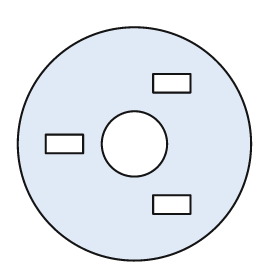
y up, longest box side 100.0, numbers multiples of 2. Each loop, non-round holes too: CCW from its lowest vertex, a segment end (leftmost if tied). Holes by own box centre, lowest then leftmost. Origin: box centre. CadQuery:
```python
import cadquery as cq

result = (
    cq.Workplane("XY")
    .moveTo(0.0, 0.0)
    .circle(50.0)
    .moveTo(8.0, -30.0)
    .lineTo(24.0, -30.0)
    .lineTo(24.0, -22.0)
    .lineTo(8.0, -22.0)
    .close()
    .moveTo(-38.0, -4.0)
    .lineTo(-22.0, -4.0)
    .lineTo(-22.0, 4.0)
    .lineTo(-38.0, 4.0)
    .close()
    .moveTo(0.0, 0.0)
    .circle(14.0)
    .moveTo(8.0, 22.0)
    .lineTo(24.0, 22.0)
    .lineTo(24.0, 30.0)
    .lineTo(8.0, 30.0)
    .close()
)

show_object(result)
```